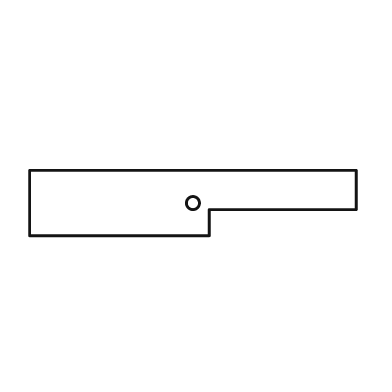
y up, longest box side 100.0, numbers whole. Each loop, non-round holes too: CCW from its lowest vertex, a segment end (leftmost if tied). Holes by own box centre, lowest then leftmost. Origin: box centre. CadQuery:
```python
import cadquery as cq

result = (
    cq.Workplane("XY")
    .moveTo(-50.0, -10.0)
    .lineTo(5.0, -10.0)
    .lineTo(5.0, -2.0)
    .lineTo(50.0, -2.0)
    .lineTo(50.0, 10.0)
    .lineTo(-50.0, 10.0)
    .close()
    .moveTo(0.0, 0.0)
    .circle(2.0)
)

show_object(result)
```